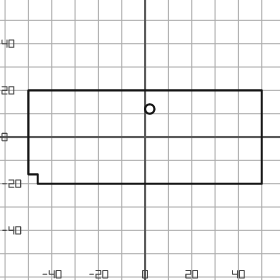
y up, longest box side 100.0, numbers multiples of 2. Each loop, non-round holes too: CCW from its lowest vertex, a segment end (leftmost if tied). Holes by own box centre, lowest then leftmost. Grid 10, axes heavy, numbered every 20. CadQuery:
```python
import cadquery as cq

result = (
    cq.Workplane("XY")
    .moveTo(-46.0, -20.0)
    .lineTo(50.0, -20.0)
    .lineTo(50.0, 20.0)
    .lineTo(-50.0, 20.0)
    .lineTo(-50.0, -16.0)
    .lineTo(-46.0, -16.0)
    .close()
    .moveTo(2.0, 12.0)
    .circle(2.0)
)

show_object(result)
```